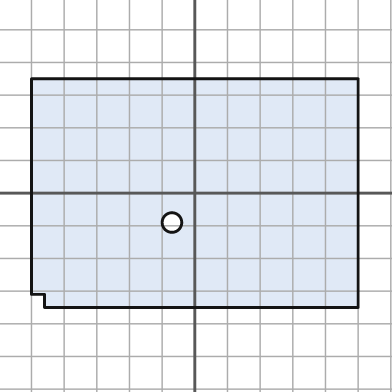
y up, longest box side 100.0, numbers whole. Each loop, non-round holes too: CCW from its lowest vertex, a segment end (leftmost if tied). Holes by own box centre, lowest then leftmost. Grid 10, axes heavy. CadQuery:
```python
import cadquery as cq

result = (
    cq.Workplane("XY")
    .moveTo(-46.0, -35.0)
    .lineTo(50.0, -35.0)
    .lineTo(50.0, 35.0)
    .lineTo(-50.0, 35.0)
    .lineTo(-50.0, -31.0)
    .lineTo(-46.0, -31.0)
    .close()
    .moveTo(-7.0, -9.0)
    .circle(3.0)
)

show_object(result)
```